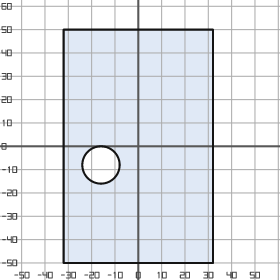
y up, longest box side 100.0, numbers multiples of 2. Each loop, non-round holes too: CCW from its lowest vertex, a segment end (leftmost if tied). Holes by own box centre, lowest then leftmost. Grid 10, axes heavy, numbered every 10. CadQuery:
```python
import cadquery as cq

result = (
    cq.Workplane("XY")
    .moveTo(-32.0, -50.0)
    .lineTo(32.0, -50.0)
    .lineTo(32.0, 50.0)
    .lineTo(-32.0, 50.0)
    .close()
    .moveTo(-16.0, -8.0)
    .circle(8.0)
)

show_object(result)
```